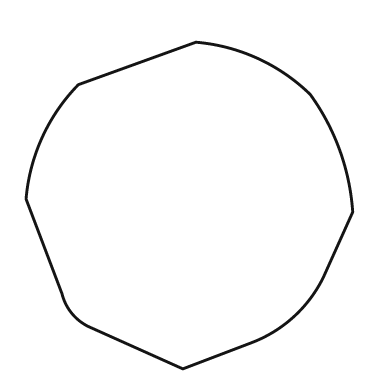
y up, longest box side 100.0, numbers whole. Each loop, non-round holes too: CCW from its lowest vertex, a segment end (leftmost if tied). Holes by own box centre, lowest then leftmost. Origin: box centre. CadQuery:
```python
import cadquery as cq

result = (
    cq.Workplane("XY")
    .moveTo(-2.0, -50.0)
    .lineTo(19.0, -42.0)
    .threePointArc((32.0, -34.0), (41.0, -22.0))
    .lineTo(50.0, -2.0)
    .threePointArc((46.0, 17.0), (37.0, 34.0))
    .threePointArc((21.0, 45.0), (2.0, 50.0))
    .lineTo(-34.0, 37.0)
    .threePointArc((-45.0, 21.0), (-50.0, 2.0))
    .lineTo(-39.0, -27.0)
    .threePointArc((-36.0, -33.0), (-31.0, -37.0))
    .close()
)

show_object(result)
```